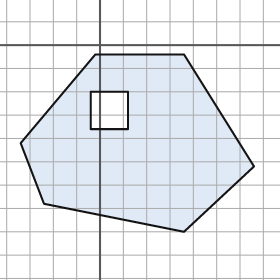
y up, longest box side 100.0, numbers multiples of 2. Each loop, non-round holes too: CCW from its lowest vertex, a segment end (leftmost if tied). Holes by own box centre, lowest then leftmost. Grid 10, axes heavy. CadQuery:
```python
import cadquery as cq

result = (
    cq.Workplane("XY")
    .moveTo(36.0, -80.0)
    .lineTo(66.0, -52.0)
    .lineTo(36.0, -4.0)
    .lineTo(-2.0, -4.0)
    .lineTo(-34.0, -42.0)
    .lineTo(-24.0, -68.0)
    .close()
    .moveTo(-4.0, -36.0)
    .lineTo(12.0, -36.0)
    .lineTo(12.0, -20.0)
    .lineTo(-4.0, -20.0)
    .close()
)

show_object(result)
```